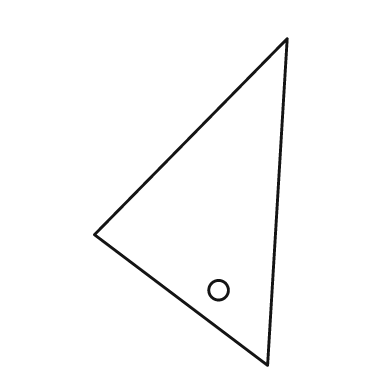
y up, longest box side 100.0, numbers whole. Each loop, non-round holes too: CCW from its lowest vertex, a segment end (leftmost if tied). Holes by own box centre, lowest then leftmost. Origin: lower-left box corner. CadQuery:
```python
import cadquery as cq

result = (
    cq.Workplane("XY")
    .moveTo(53.0, 0.0)
    .lineTo(59.0, 100.0)
    .lineTo(0.0, 40.0)
    .close()
    .moveTo(38.0, 23.0)
    .circle(3.0)
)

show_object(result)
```